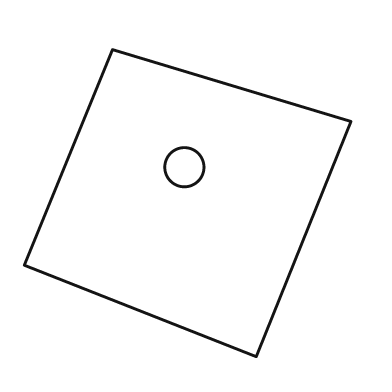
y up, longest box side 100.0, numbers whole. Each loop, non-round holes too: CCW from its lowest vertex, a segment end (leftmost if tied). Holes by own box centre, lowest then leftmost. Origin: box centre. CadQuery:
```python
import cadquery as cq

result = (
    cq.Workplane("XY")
    .moveTo(21.0, -47.0)
    .lineTo(50.0, 25.0)
    .lineTo(-23.0, 47.0)
    .lineTo(-50.0, -19.0)
    .close()
    .moveTo(-1.0, 11.0)
    .circle(6.0)
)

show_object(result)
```